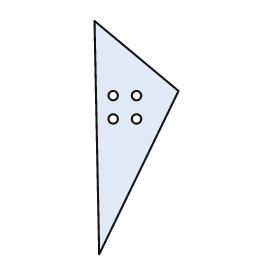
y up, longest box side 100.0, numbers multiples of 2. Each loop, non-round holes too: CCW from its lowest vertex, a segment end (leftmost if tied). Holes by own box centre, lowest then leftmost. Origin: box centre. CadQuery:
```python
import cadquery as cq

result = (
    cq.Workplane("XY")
    .moveTo(-16.0, -50.0)
    .lineTo(18.0, 20.0)
    .lineTo(-18.0, 50.0)
    .close()
    .moveTo(-10.0, 8.0)
    .circle(2.0)
    .moveTo(0.0, 8.0)
    .circle(2.0)
    .moveTo(-10.0, 18.0)
    .circle(2.0)
    .moveTo(0.0, 18.0)
    .circle(2.0)
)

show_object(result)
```